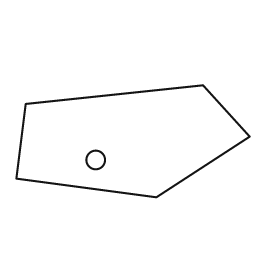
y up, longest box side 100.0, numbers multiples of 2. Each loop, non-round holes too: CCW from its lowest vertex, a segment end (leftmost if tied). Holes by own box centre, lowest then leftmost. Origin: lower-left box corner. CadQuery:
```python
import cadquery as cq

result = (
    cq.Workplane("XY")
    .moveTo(60.0, 0.0)
    .lineTo(100.0, 26.0)
    .lineTo(80.0, 48.0)
    .lineTo(4.0, 40.0)
    .lineTo(0.0, 8.0)
    .close()
    .moveTo(34.0, 16.0)
    .circle(4.0)
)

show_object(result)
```